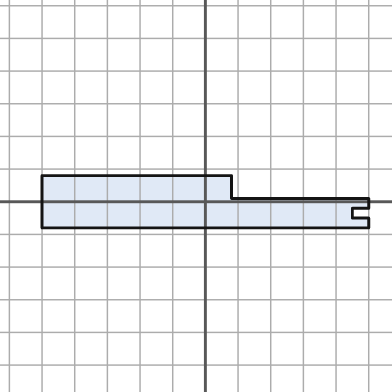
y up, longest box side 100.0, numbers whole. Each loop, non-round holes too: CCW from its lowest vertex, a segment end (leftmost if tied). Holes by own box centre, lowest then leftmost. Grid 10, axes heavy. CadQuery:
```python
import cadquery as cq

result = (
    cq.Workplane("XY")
    .moveTo(-50.0, -8.0)
    .lineTo(50.0, -8.0)
    .lineTo(50.0, -5.0)
    .lineTo(45.0, -5.0)
    .lineTo(45.0, -2.0)
    .lineTo(50.0, -2.0)
    .lineTo(50.0, 1.0)
    .lineTo(8.0, 1.0)
    .lineTo(8.0, 8.0)
    .lineTo(-50.0, 8.0)
    .close()
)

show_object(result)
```